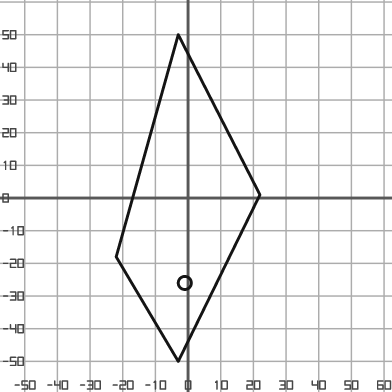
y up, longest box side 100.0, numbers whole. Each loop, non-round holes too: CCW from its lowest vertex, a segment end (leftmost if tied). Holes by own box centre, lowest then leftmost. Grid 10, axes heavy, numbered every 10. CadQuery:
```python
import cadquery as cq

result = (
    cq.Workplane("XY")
    .moveTo(-3.0, -50.0)
    .lineTo(22.0, 1.0)
    .lineTo(-3.0, 50.0)
    .lineTo(-22.0, -18.0)
    .close()
    .moveTo(-1.0, -26.0)
    .circle(2.0)
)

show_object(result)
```